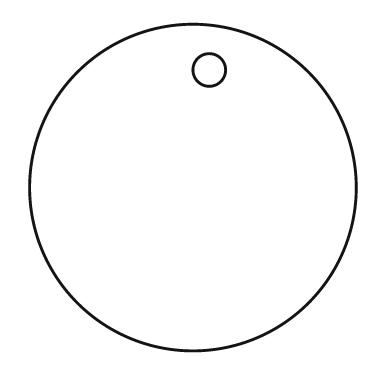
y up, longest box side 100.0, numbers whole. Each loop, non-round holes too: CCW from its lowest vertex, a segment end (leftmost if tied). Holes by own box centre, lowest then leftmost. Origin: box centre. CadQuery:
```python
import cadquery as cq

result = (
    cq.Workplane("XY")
    .moveTo(0.0, 0.0)
    .circle(50.0)
    .moveTo(5.0, 36.0)
    .circle(5.0)
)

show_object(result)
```